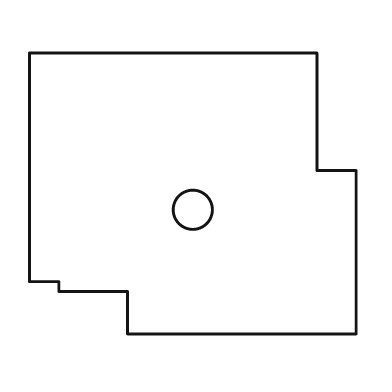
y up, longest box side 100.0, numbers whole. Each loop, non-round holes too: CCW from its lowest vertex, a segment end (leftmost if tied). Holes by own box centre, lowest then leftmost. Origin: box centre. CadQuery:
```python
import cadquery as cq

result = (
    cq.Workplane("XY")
    .moveTo(-20.0, -43.0)
    .lineTo(50.0, -43.0)
    .lineTo(50.0, 7.0)
    .lineTo(38.0, 7.0)
    .lineTo(38.0, 43.0)
    .lineTo(-50.0, 43.0)
    .lineTo(-50.0, -27.0)
    .lineTo(-41.0, -27.0)
    .lineTo(-41.0, -30.0)
    .lineTo(-20.0, -30.0)
    .close()
    .moveTo(0.0, -5.0)
    .circle(6.0)
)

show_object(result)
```